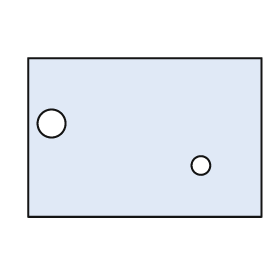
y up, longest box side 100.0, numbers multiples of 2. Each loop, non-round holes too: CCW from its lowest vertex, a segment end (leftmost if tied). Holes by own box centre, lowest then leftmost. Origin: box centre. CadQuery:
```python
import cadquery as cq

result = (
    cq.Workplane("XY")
    .moveTo(-50.0, -34.0)
    .lineTo(50.0, -34.0)
    .lineTo(50.0, 34.0)
    .lineTo(-50.0, 34.0)
    .close()
    .moveTo(24.0, -12.0)
    .circle(4.0)
    .moveTo(-40.0, 6.0)
    .circle(6.0)
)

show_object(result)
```